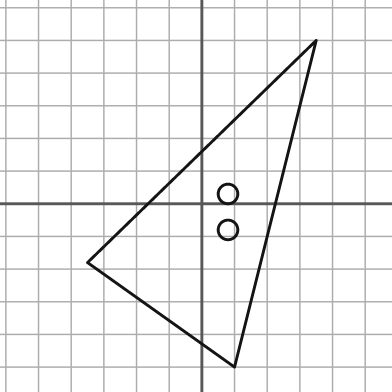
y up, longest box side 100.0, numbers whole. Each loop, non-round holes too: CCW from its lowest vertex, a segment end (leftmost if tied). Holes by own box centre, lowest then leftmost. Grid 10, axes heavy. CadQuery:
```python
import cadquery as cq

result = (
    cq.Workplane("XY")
    .moveTo(10.0, -50.0)
    .lineTo(35.0, 50.0)
    .lineTo(-35.0, -18.0)
    .close()
    .moveTo(8.0, -8.0)
    .circle(3.0)
    .moveTo(8.0, 3.0)
    .circle(3.0)
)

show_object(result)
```